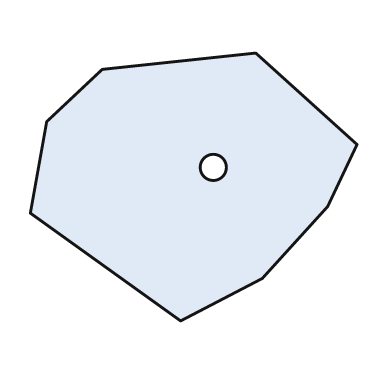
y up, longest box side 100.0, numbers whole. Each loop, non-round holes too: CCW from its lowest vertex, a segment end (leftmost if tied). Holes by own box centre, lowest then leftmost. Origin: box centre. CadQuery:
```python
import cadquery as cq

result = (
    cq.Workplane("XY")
    .moveTo(-4.0, -41.0)
    .lineTo(21.0, -28.0)
    .lineTo(41.0, -6.0)
    .lineTo(50.0, 13.0)
    .lineTo(19.0, 41.0)
    .lineTo(-28.0, 36.0)
    .lineTo(-45.0, 20.0)
    .lineTo(-50.0, -8.0)
    .close()
    .moveTo(6.0, 6.0)
    .circle(4.0)
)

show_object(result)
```